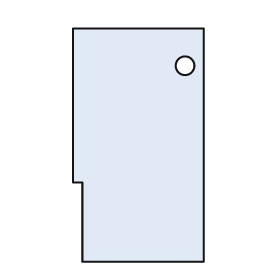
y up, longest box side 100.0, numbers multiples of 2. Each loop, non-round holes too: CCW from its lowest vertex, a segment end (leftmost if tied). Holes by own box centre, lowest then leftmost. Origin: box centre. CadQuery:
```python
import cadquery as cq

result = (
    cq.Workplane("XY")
    .moveTo(-24.0, -50.0)
    .lineTo(28.0, -50.0)
    .lineTo(28.0, 50.0)
    .lineTo(-28.0, 50.0)
    .lineTo(-28.0, -16.0)
    .lineTo(-24.0, -16.0)
    .close()
    .moveTo(20.0, 34.0)
    .circle(4.0)
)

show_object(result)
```